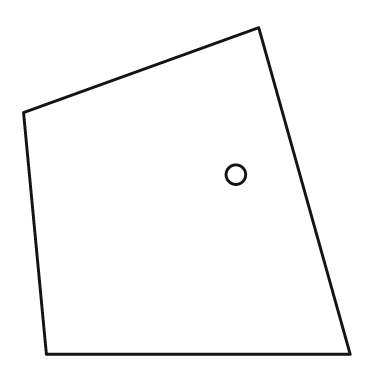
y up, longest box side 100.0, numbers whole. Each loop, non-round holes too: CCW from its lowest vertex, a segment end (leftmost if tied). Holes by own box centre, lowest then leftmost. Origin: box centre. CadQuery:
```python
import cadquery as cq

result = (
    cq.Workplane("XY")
    .moveTo(-43.0, -50.0)
    .lineTo(50.0, -50.0)
    .lineTo(22.0, 50.0)
    .lineTo(-50.0, 24.0)
    .close()
    .moveTo(15.0, 5.0)
    .circle(3.0)
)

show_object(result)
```